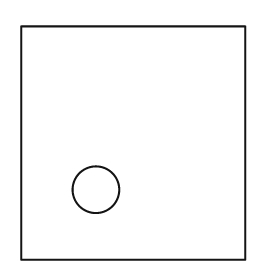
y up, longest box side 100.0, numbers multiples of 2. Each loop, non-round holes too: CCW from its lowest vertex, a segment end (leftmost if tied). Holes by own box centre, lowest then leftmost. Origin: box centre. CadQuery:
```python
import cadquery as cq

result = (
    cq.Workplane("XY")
    .moveTo(-48.0, -50.0)
    .lineTo(48.0, -50.0)
    .lineTo(48.0, 50.0)
    .lineTo(-48.0, 50.0)
    .close()
    .moveTo(-16.0, -20.0)
    .circle(10.0)
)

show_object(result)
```